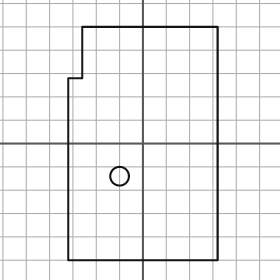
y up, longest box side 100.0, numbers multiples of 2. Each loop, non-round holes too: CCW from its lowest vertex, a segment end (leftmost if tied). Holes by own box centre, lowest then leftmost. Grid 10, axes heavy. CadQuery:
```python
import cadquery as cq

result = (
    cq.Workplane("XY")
    .moveTo(-32.0, -50.0)
    .lineTo(32.0, -50.0)
    .lineTo(32.0, 50.0)
    .lineTo(-26.0, 50.0)
    .lineTo(-26.0, 28.0)
    .lineTo(-32.0, 28.0)
    .close()
    .moveTo(-10.0, -14.0)
    .circle(4.0)
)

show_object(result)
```